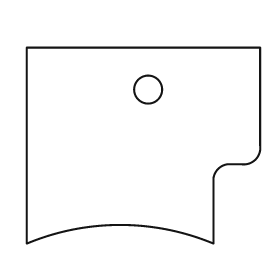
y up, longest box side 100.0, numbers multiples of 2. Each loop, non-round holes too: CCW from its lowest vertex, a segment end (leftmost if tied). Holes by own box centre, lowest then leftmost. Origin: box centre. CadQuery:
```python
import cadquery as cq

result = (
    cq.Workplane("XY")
    .moveTo(-50.0, -42.0)
    .threePointArc((-10.0, -34.0), (30.0, -42.0))
    .lineTo(30.0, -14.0)
    .threePointArc((32.0, -10.0), (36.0, -8.0))
    .lineTo(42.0, -8.0)
    .threePointArc((48.0, -6.0), (50.0, 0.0))
    .lineTo(50.0, 42.0)
    .lineTo(-50.0, 42.0)
    .close()
    .moveTo(2.0, 24.0)
    .circle(6.0)
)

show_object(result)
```